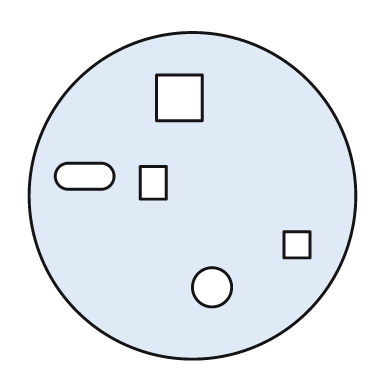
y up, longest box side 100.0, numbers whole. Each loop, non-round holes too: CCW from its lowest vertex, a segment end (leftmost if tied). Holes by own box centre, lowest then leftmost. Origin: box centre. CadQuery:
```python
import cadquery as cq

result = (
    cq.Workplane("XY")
    .moveTo(0.0, 0.0)
    .circle(50.0)
    .moveTo(6.0, -28.0)
    .circle(6.0)
    .moveTo(28.0, -19.0)
    .lineTo(36.0, -19.0)
    .lineTo(36.0, -11.0)
    .lineTo(28.0, -11.0)
    .close()
    .moveTo(-16.0, -1.0)
    .lineTo(-8.0, -1.0)
    .lineTo(-8.0, 9.0)
    .lineTo(-16.0, 9.0)
    .close()
    .moveTo(-38.0, 2.0)
    .lineTo(-28.0, 2.0)
    .threePointArc((-24.0, 6.0), (-28.0, 10.0))
    .lineTo(-38.0, 10.0)
    .threePointArc((-42.0, 6.0), (-38.0, 2.0))
    .close()
    .moveTo(-11.0, 23.0)
    .lineTo(3.0, 23.0)
    .lineTo(3.0, 37.0)
    .lineTo(-11.0, 37.0)
    .close()
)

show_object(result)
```